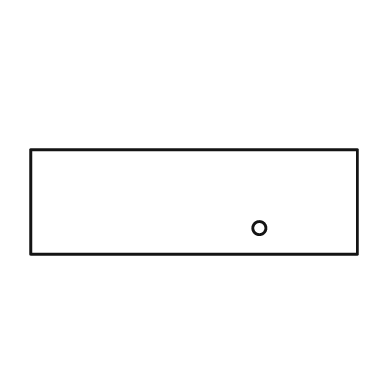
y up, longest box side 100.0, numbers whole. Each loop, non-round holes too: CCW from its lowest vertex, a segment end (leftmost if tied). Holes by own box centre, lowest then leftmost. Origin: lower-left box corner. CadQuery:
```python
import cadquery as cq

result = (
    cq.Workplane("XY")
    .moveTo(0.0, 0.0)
    .lineTo(100.0, 0.0)
    .lineTo(100.0, 32.0)
    .lineTo(0.0, 32.0)
    .close()
    .moveTo(70.0, 8.0)
    .circle(2.0)
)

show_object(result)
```